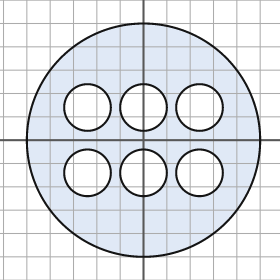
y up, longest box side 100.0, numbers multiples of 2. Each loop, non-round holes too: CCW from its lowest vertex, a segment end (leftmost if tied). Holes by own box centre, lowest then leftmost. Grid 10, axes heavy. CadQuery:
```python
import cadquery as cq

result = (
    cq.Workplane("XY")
    .moveTo(0.0, 0.0)
    .circle(50.0)
    .moveTo(-24.0, -14.0)
    .circle(10.0)
    .moveTo(0.0, -14.0)
    .circle(10.0)
    .moveTo(24.0, -14.0)
    .circle(10.0)
    .moveTo(-24.0, 14.0)
    .circle(10.0)
    .moveTo(0.0, 14.0)
    .circle(10.0)
    .moveTo(24.0, 14.0)
    .circle(10.0)
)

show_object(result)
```